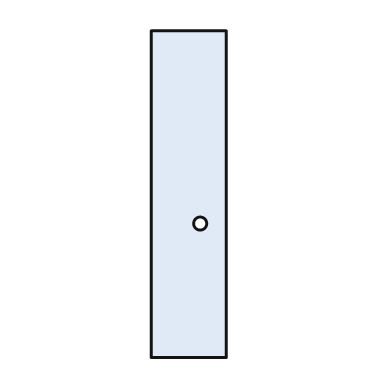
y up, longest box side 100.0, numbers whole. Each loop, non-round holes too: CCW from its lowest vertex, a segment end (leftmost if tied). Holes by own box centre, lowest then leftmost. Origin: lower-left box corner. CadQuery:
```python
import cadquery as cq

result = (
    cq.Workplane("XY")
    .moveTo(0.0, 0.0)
    .lineTo(23.0, 0.0)
    .lineTo(23.0, 100.0)
    .lineTo(0.0, 100.0)
    .close()
    .moveTo(15.0, 41.0)
    .circle(2.0)
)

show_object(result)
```